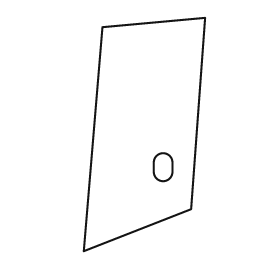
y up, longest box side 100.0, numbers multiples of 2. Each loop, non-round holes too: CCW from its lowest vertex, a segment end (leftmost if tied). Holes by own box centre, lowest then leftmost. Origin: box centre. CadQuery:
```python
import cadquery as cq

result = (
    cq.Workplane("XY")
    .moveTo(-26.0, -50.0)
    .lineTo(20.0, -32.0)
    .lineTo(26.0, 50.0)
    .lineTo(-18.0, 46.0)
    .close()
    .moveTo(4.0, -16.0)
    .threePointArc((8.0, -20.0), (12.0, -16.0))
    .lineTo(12.0, -12.0)
    .threePointArc((8.0, -8.0), (4.0, -12.0))
    .close()
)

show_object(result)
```